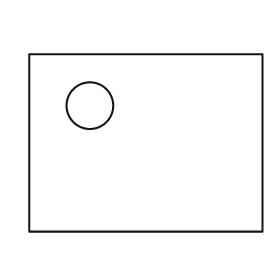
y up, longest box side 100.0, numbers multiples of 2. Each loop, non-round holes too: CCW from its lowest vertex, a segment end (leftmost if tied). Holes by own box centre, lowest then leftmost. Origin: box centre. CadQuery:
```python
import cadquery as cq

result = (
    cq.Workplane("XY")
    .moveTo(-50.0, -38.0)
    .lineTo(50.0, -38.0)
    .lineTo(50.0, 38.0)
    .lineTo(-50.0, 38.0)
    .close()
    .moveTo(-24.0, 16.0)
    .circle(10.0)
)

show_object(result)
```